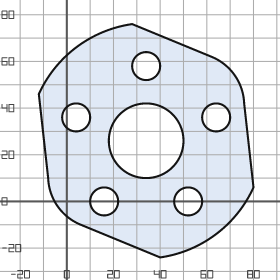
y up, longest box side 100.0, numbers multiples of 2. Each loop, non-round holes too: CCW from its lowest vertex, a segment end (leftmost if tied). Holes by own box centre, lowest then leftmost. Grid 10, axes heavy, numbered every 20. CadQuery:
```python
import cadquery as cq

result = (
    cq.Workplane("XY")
    .moveTo(40.0, -24.0)
    .threePointArc((64.0, -14.0), (80.0, 6.0))
    .lineTo(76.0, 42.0)
    .threePointArc((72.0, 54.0), (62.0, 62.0))
    .lineTo(28.0, 76.0)
    .threePointArc((4.0, 66.0), (-12.0, 46.0))
    .lineTo(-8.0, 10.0)
    .threePointArc((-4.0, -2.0), (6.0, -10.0))
    .close()
    .moveTo(16.0, 0.0)
    .circle(6.0)
    .moveTo(52.0, 0.0)
    .circle(6.0)
    .moveTo(34.0, 26.0)
    .circle(16.0)
    .moveTo(4.0, 36.0)
    .circle(6.0)
    .moveTo(64.0, 36.0)
    .circle(6.0)
    .moveTo(34.0, 58.0)
    .circle(6.0)
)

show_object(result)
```